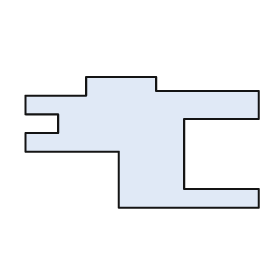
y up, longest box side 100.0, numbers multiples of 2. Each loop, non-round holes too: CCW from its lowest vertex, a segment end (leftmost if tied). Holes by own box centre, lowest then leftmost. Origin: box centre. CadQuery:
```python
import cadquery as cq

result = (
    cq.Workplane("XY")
    .moveTo(-10.0, -28.0)
    .lineTo(50.0, -28.0)
    .lineTo(50.0, -20.0)
    .lineTo(18.0, -20.0)
    .lineTo(18.0, 10.0)
    .lineTo(50.0, 10.0)
    .lineTo(50.0, 22.0)
    .lineTo(6.0, 22.0)
    .lineTo(6.0, 28.0)
    .lineTo(-24.0, 28.0)
    .lineTo(-24.0, 20.0)
    .lineTo(-50.0, 20.0)
    .lineTo(-50.0, 12.0)
    .lineTo(-36.0, 12.0)
    .lineTo(-36.0, 4.0)
    .lineTo(-50.0, 4.0)
    .lineTo(-50.0, -4.0)
    .lineTo(-10.0, -4.0)
    .close()
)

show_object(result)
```